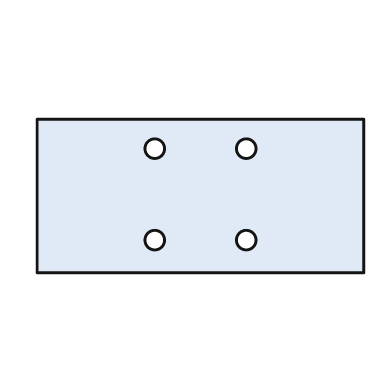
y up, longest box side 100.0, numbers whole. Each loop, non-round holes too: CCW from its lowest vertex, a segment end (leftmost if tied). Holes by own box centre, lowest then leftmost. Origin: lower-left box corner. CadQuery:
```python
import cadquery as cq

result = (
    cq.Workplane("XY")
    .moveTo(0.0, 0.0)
    .lineTo(100.0, 0.0)
    .lineTo(100.0, 47.0)
    .lineTo(0.0, 47.0)
    .close()
    .moveTo(36.0, 10.0)
    .circle(3.0)
    .moveTo(64.0, 10.0)
    .circle(3.0)
    .moveTo(36.0, 38.0)
    .circle(3.0)
    .moveTo(64.0, 38.0)
    .circle(3.0)
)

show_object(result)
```